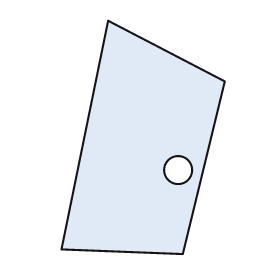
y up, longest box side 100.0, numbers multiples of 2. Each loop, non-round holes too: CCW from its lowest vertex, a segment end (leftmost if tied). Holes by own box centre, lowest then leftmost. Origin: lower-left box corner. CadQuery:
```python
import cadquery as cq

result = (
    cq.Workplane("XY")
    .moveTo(52.0, 0.0)
    .lineTo(70.0, 74.0)
    .lineTo(20.0, 100.0)
    .lineTo(0.0, 2.0)
    .close()
    .moveTo(50.0, 36.0)
    .circle(6.0)
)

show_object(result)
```